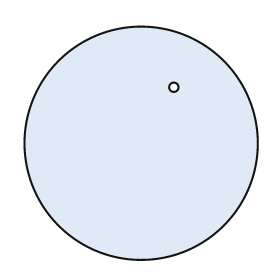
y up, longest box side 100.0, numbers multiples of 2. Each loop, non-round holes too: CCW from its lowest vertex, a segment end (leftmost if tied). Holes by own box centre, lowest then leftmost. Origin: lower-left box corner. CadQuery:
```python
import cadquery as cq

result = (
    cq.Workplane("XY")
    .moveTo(50.0, 50.0)
    .circle(50.0)
    .moveTo(64.0, 74.0)
    .circle(2.0)
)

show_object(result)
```